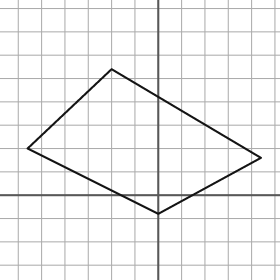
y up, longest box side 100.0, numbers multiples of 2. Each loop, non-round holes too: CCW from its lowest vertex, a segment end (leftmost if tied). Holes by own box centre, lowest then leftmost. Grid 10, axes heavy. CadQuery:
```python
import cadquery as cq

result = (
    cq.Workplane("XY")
    .moveTo(0.0, -8.0)
    .lineTo(44.0, 16.0)
    .lineTo(-20.0, 54.0)
    .lineTo(-56.0, 20.0)
    .close()
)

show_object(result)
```